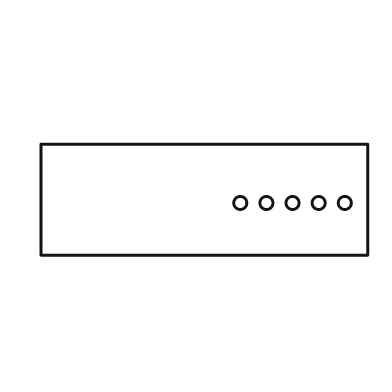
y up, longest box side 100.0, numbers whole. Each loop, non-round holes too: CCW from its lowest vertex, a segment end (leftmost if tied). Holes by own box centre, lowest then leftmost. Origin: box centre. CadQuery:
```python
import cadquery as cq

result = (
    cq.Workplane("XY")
    .moveTo(-50.0, -17.0)
    .lineTo(50.0, -17.0)
    .lineTo(50.0, 17.0)
    .lineTo(-50.0, 17.0)
    .close()
    .moveTo(11.0, -1.0)
    .circle(2.0)
    .moveTo(19.0, -1.0)
    .circle(2.0)
    .moveTo(27.0, -1.0)
    .circle(2.0)
    .moveTo(35.0, -1.0)
    .circle(2.0)
    .moveTo(43.0, -1.0)
    .circle(2.0)
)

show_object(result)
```